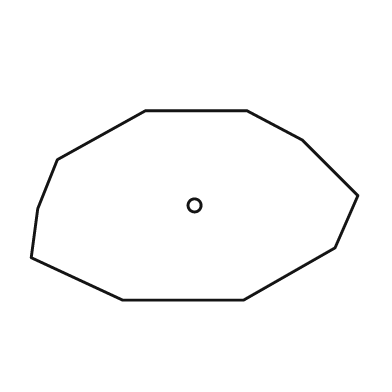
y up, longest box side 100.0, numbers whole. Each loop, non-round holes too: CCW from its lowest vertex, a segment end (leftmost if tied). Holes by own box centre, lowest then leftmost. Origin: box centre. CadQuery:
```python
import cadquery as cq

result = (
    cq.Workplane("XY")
    .moveTo(-22.0, -29.0)
    .lineTo(15.0, -29.0)
    .lineTo(43.0, -13.0)
    .lineTo(50.0, 3.0)
    .lineTo(33.0, 20.0)
    .lineTo(16.0, 29.0)
    .lineTo(-15.0, 29.0)
    .lineTo(-42.0, 14.0)
    .lineTo(-48.0, -1.0)
    .lineTo(-50.0, -16.0)
    .close()
    .moveTo(0.0, 0.0)
    .circle(2.0)
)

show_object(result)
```